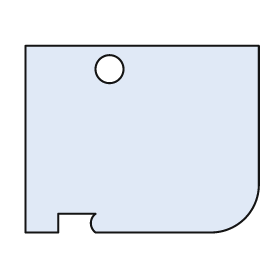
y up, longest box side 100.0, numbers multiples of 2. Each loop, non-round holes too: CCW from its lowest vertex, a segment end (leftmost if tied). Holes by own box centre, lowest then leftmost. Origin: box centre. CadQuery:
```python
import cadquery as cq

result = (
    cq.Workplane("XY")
    .moveTo(-50.0, -40.0)
    .lineTo(-36.0, -40.0)
    .lineTo(-36.0, -32.0)
    .lineTo(-20.0, -32.0)
    .threePointArc((-22.0, -36.0), (-20.0, -40.0))
    .lineTo(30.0, -40.0)
    .threePointArc((44.0, -34.0), (50.0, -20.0))
    .lineTo(50.0, 40.0)
    .lineTo(-50.0, 40.0)
    .close()
    .moveTo(-14.0, 30.0)
    .circle(6.0)
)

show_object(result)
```